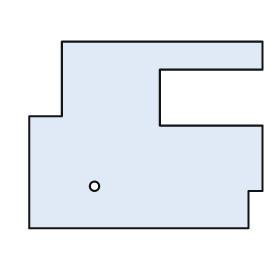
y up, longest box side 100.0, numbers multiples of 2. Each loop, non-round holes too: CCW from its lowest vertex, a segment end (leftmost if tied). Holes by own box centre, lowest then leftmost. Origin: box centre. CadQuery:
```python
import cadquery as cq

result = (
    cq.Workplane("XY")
    .moveTo(-50.0, -40.0)
    .lineTo(44.0, -40.0)
    .lineTo(44.0, -24.0)
    .lineTo(50.0, -24.0)
    .lineTo(50.0, 4.0)
    .lineTo(6.0, 4.0)
    .lineTo(6.0, 28.0)
    .lineTo(50.0, 28.0)
    .lineTo(50.0, 40.0)
    .lineTo(-36.0, 40.0)
    .lineTo(-36.0, 8.0)
    .lineTo(-50.0, 8.0)
    .close()
    .moveTo(-22.0, -22.0)
    .circle(2.0)
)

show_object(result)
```